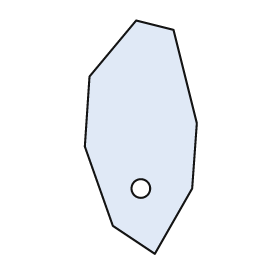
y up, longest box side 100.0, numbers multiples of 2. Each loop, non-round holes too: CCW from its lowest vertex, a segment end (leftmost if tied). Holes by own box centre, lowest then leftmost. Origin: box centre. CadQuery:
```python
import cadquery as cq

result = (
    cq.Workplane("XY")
    .moveTo(6.0, -50.0)
    .lineTo(22.0, -22.0)
    .lineTo(24.0, 6.0)
    .lineTo(14.0, 46.0)
    .lineTo(-2.0, 50.0)
    .lineTo(-22.0, 26.0)
    .lineTo(-24.0, -4.0)
    .lineTo(-12.0, -38.0)
    .close()
    .moveTo(0.0, -22.0)
    .circle(4.0)
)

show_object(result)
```